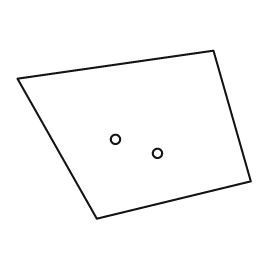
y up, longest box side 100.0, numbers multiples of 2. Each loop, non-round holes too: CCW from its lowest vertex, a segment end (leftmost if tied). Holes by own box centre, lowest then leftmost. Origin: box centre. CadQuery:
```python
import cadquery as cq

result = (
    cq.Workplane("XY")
    .moveTo(-16.0, -36.0)
    .lineTo(50.0, -20.0)
    .lineTo(34.0, 36.0)
    .lineTo(-50.0, 24.0)
    .close()
    .moveTo(10.0, -8.0)
    .circle(2.0)
    .moveTo(-8.0, -2.0)
    .circle(2.0)
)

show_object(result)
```